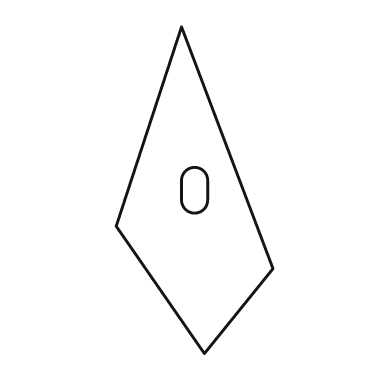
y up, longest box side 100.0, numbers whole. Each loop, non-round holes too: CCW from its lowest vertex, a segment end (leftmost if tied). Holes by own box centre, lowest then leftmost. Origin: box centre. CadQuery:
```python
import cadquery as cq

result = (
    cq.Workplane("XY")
    .moveTo(3.0, -50.0)
    .lineTo(24.0, -24.0)
    .lineTo(-4.0, 50.0)
    .lineTo(-24.0, -11.0)
    .close()
    .moveTo(-4.0, -3.0)
    .threePointArc((0.0, -7.0), (4.0, -3.0))
    .lineTo(4.0, 3.0)
    .threePointArc((0.0, 7.0), (-4.0, 3.0))
    .close()
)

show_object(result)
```